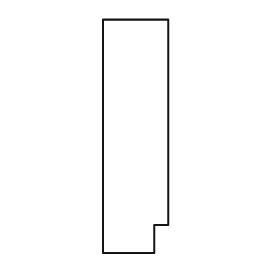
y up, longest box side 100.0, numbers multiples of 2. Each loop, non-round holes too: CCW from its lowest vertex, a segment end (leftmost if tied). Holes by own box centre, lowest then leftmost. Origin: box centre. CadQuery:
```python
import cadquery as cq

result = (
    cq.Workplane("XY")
    .moveTo(-14.0, -50.0)
    .lineTo(8.0, -50.0)
    .lineTo(8.0, -38.0)
    .lineTo(14.0, -38.0)
    .lineTo(14.0, 50.0)
    .lineTo(-14.0, 50.0)
    .close()
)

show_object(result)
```